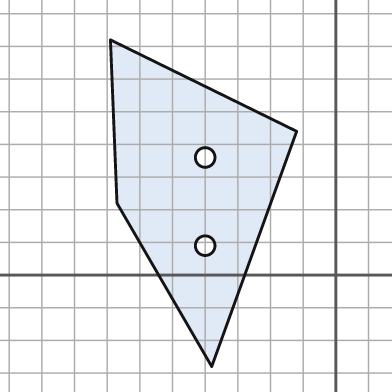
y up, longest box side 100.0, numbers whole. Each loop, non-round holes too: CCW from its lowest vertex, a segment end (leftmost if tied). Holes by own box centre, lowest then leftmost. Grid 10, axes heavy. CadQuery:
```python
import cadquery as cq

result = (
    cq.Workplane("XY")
    .moveTo(-38.0, -28.0)
    .lineTo(-12.0, 44.0)
    .lineTo(-69.0, 72.0)
    .lineTo(-67.0, 22.0)
    .close()
    .moveTo(-40.0, 9.0)
    .circle(3.0)
    .moveTo(-40.0, 36.0)
    .circle(3.0)
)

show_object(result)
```